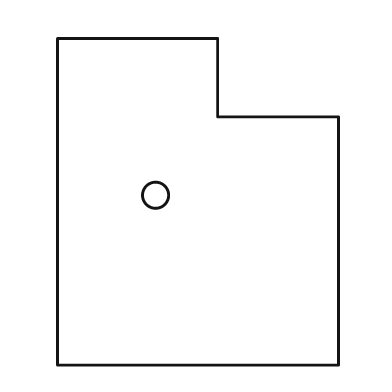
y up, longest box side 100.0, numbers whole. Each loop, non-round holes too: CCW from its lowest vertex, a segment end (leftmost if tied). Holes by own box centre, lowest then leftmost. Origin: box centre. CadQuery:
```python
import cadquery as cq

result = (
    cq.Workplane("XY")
    .moveTo(-43.0, -50.0)
    .lineTo(43.0, -50.0)
    .lineTo(43.0, 26.0)
    .lineTo(6.0, 26.0)
    .lineTo(6.0, 50.0)
    .lineTo(-43.0, 50.0)
    .close()
    .moveTo(-13.0, 2.0)
    .circle(4.0)
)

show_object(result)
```